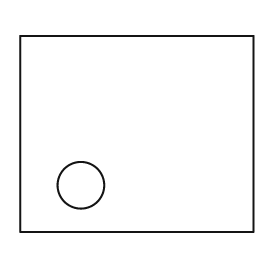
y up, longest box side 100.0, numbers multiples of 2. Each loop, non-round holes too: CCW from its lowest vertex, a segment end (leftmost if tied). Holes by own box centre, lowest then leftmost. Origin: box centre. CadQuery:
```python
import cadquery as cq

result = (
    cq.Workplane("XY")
    .moveTo(-50.0, -42.0)
    .lineTo(50.0, -42.0)
    .lineTo(50.0, 42.0)
    .lineTo(-50.0, 42.0)
    .close()
    .moveTo(-24.0, -22.0)
    .circle(10.0)
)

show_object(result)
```